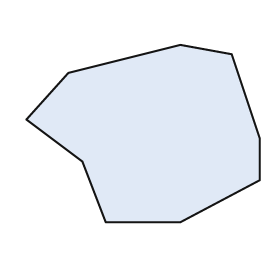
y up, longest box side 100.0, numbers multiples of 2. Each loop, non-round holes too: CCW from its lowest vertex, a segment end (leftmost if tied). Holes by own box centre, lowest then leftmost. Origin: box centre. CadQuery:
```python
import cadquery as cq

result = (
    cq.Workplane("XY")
    .moveTo(-16.0, -38.0)
    .lineTo(16.0, -38.0)
    .lineTo(50.0, -20.0)
    .lineTo(50.0, -2.0)
    .lineTo(38.0, 34.0)
    .lineTo(16.0, 38.0)
    .lineTo(-32.0, 26.0)
    .lineTo(-50.0, 6.0)
    .lineTo(-26.0, -12.0)
    .close()
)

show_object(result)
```